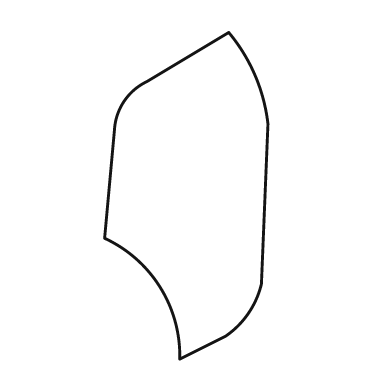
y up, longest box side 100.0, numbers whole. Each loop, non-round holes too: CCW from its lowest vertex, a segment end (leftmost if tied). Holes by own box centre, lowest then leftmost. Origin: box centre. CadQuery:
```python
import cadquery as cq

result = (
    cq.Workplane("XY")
    .moveTo(-2.0, -50.0)
    .lineTo(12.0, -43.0)
    .threePointArc((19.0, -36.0), (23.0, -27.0))
    .lineTo(25.0, 22.0)
    .threePointArc((21.0, 37.0), (13.0, 50.0))
    .lineTo(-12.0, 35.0)
    .threePointArc((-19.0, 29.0), (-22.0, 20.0))
    .lineTo(-25.0, -13.0)
    .threePointArc((-8.0, -28.0), (-2.0, -50.0))
    .close()
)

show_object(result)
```